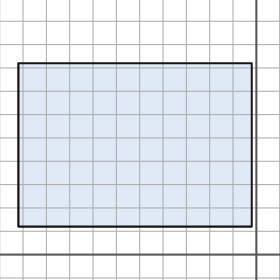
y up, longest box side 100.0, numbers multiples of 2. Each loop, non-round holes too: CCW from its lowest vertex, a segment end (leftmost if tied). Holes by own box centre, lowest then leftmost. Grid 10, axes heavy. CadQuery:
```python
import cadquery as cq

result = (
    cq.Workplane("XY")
    .moveTo(-102.0, 12.0)
    .lineTo(-2.0, 12.0)
    .lineTo(-2.0, 82.0)
    .lineTo(-102.0, 82.0)
    .close()
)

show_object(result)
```